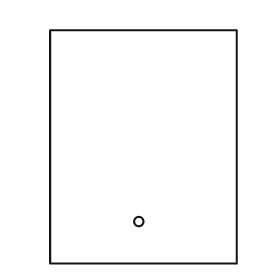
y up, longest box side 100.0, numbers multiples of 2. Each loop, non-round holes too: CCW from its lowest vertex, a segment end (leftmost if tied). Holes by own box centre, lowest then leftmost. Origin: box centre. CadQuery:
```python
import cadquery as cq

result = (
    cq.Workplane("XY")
    .moveTo(-40.0, -50.0)
    .lineTo(40.0, -50.0)
    .lineTo(40.0, 50.0)
    .lineTo(-40.0, 50.0)
    .close()
    .moveTo(-2.0, -32.0)
    .circle(2.0)
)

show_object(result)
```